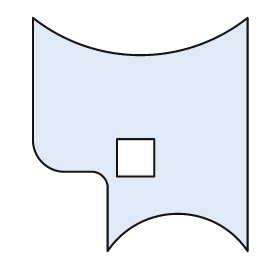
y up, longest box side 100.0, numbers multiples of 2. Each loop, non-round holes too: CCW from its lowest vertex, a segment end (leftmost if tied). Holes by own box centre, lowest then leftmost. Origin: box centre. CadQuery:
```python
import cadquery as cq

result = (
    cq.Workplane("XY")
    .moveTo(-14.0, -50.0)
    .threePointArc((16.0, -34.0), (46.0, -50.0))
    .lineTo(46.0, 50.0)
    .threePointArc((0.0, 34.0), (-46.0, 50.0))
    .lineTo(-46.0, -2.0)
    .threePointArc((-42.0, -12.0), (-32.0, -16.0))
    .lineTo(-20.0, -16.0)
    .threePointArc((-16.0, -18.0), (-14.0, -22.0))
    .close()
    .moveTo(-10.0, -18.0)
    .lineTo(6.0, -18.0)
    .lineTo(6.0, -2.0)
    .lineTo(-10.0, -2.0)
    .close()
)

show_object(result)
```